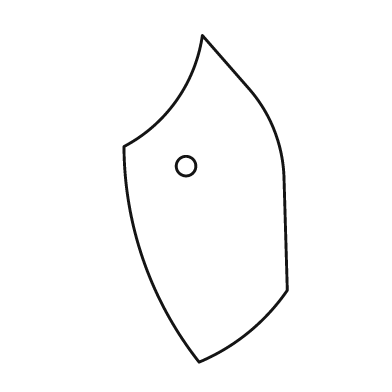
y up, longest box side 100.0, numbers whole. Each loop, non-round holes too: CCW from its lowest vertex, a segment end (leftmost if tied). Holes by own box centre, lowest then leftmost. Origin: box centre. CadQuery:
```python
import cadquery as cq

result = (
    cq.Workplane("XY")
    .moveTo(-2.0, -50.0)
    .threePointArc((13.0, -41.0), (25.0, -28.0))
    .lineTo(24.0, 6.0)
    .threePointArc((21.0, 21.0), (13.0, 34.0))
    .lineTo(-1.0, 50.0)
    .threePointArc((-9.0, 30.0), (-25.0, 16.0))
    .threePointArc((-19.0, -19.0), (-2.0, -50.0))
    .close()
    .moveTo(-6.0, 10.0)
    .circle(3.0)
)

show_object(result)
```